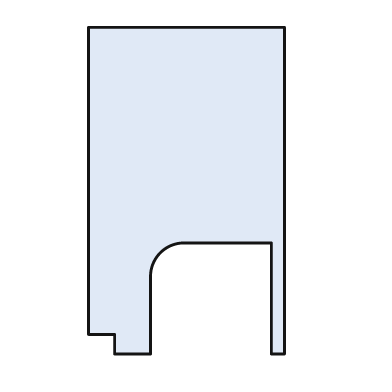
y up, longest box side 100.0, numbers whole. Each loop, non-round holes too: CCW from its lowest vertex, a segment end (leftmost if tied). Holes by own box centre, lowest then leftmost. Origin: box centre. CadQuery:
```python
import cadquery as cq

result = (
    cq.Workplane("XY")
    .moveTo(-22.0, -50.0)
    .lineTo(-11.0, -50.0)
    .lineTo(-11.0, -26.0)
    .threePointArc((-8.0, -19.0), (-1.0, -16.0))
    .lineTo(26.0, -16.0)
    .lineTo(26.0, -50.0)
    .lineTo(30.0, -50.0)
    .lineTo(30.0, 50.0)
    .lineTo(-30.0, 50.0)
    .lineTo(-30.0, -44.0)
    .lineTo(-22.0, -44.0)
    .close()
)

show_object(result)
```